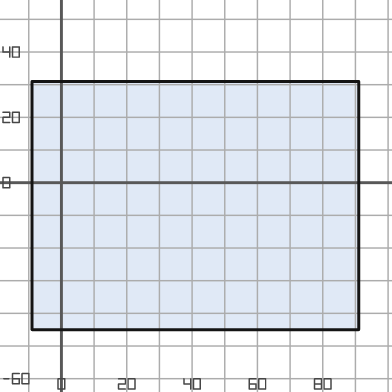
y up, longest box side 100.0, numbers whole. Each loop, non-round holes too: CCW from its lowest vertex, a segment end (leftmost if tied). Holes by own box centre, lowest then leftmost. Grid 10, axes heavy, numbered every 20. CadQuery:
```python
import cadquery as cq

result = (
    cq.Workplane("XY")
    .moveTo(-9.0, -45.0)
    .lineTo(91.0, -45.0)
    .lineTo(91.0, 31.0)
    .lineTo(-9.0, 31.0)
    .close()
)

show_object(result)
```